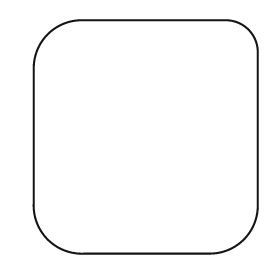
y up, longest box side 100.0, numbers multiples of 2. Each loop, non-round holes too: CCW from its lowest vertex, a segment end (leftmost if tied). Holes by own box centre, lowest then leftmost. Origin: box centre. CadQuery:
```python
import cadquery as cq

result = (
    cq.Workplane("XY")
    .moveTo(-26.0, -50.0)
    .lineTo(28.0, -50.0)
    .threePointArc((42.0, -44.0), (48.0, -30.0))
    .lineTo(48.0, 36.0)
    .threePointArc((44.0, 46.0), (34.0, 50.0))
    .lineTo(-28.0, 50.0)
    .threePointArc((-42.0, 44.0), (-48.0, 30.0))
    .lineTo(-48.0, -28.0)
    .threePointArc((-42.0, -44.0), (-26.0, -50.0))
    .close()
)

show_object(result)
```